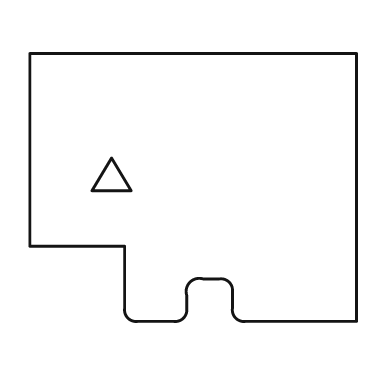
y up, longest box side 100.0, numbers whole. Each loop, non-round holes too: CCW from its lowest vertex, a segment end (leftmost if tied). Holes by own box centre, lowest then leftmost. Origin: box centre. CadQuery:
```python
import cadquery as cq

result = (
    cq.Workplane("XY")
    .moveTo(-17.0, -41.0)
    .lineTo(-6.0, -41.0)
    .threePointArc((-3.0, -40.0), (-2.0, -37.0))
    .lineTo(-2.0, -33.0)
    .threePointArc((-1.0, -29.0), (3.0, -28.0))
    .lineTo(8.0, -28.0)
    .threePointArc((11.0, -29.0), (12.0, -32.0))
    .lineTo(12.0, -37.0)
    .threePointArc((13.0, -40.0), (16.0, -41.0))
    .lineTo(50.0, -41.0)
    .lineTo(50.0, 41.0)
    .lineTo(-50.0, 41.0)
    .lineTo(-50.0, -18.0)
    .lineTo(-21.0, -18.0)
    .lineTo(-21.0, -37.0)
    .threePointArc((-20.0, -40.0), (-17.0, -41.0))
    .close()
    .moveTo(-31.0, -1.0)
    .lineTo(-19.0, -1.0)
    .lineTo(-25.0, 9.0)
    .close()
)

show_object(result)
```